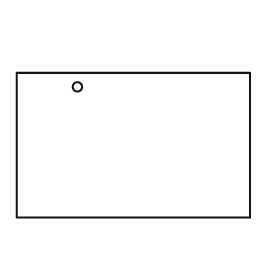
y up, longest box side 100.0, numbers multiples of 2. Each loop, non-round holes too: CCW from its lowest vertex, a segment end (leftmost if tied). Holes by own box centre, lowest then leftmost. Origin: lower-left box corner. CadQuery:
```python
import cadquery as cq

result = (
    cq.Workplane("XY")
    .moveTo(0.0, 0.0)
    .lineTo(100.0, 0.0)
    .lineTo(100.0, 62.0)
    .lineTo(0.0, 62.0)
    .close()
    .moveTo(26.0, 56.0)
    .circle(2.0)
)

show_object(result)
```